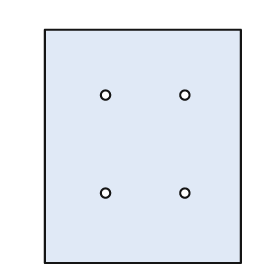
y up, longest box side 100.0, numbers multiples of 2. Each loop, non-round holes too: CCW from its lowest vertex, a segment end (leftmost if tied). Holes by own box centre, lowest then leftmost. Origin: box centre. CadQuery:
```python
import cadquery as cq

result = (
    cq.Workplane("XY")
    .moveTo(-42.0, -50.0)
    .lineTo(42.0, -50.0)
    .lineTo(42.0, 50.0)
    .lineTo(-42.0, 50.0)
    .close()
    .moveTo(-16.0, -20.0)
    .circle(2.0)
    .moveTo(18.0, -20.0)
    .circle(2.0)
    .moveTo(-16.0, 22.0)
    .circle(2.0)
    .moveTo(18.0, 22.0)
    .circle(2.0)
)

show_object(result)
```